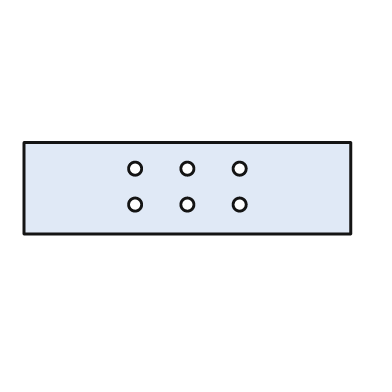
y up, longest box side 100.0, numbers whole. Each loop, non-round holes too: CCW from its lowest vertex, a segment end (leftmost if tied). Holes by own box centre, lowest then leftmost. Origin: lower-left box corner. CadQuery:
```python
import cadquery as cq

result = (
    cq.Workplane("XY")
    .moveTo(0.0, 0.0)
    .lineTo(100.0, 0.0)
    .lineTo(100.0, 28.0)
    .lineTo(0.0, 28.0)
    .close()
    .moveTo(34.0, 9.0)
    .circle(2.0)
    .moveTo(50.0, 9.0)
    .circle(2.0)
    .moveTo(66.0, 9.0)
    .circle(2.0)
    .moveTo(34.0, 20.0)
    .circle(2.0)
    .moveTo(50.0, 20.0)
    .circle(2.0)
    .moveTo(66.0, 20.0)
    .circle(2.0)
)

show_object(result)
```